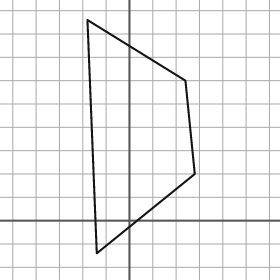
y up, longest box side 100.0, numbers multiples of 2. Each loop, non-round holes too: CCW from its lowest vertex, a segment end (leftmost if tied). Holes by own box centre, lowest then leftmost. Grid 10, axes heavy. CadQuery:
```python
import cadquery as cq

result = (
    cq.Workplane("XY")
    .moveTo(-14.0, -14.0)
    .lineTo(28.0, 20.0)
    .lineTo(24.0, 60.0)
    .lineTo(-18.0, 86.0)
    .close()
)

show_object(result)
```